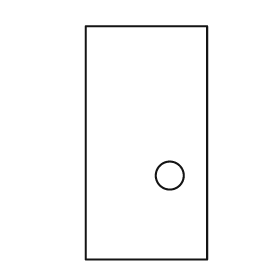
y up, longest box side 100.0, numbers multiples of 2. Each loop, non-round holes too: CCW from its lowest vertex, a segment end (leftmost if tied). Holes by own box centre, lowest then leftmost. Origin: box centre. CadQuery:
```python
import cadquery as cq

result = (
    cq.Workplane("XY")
    .moveTo(-26.0, -50.0)
    .lineTo(26.0, -50.0)
    .lineTo(26.0, 50.0)
    .lineTo(-26.0, 50.0)
    .close()
    .moveTo(10.0, -14.0)
    .circle(6.0)
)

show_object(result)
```